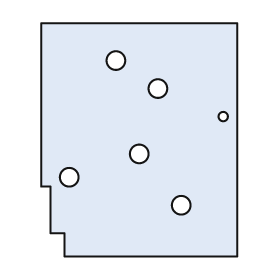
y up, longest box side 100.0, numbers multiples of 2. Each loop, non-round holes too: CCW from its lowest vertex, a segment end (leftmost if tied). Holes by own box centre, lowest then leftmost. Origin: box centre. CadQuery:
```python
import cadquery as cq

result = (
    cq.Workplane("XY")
    .moveTo(-32.0, -50.0)
    .lineTo(42.0, -50.0)
    .lineTo(42.0, 50.0)
    .lineTo(-42.0, 50.0)
    .lineTo(-42.0, -20.0)
    .lineTo(-38.0, -20.0)
    .lineTo(-38.0, -40.0)
    .lineTo(-32.0, -40.0)
    .close()
    .moveTo(18.0, -28.0)
    .circle(4.0)
    .moveTo(-30.0, -16.0)
    .circle(4.0)
    .moveTo(0.0, -6.0)
    .circle(4.0)
    .moveTo(36.0, 10.0)
    .circle(2.0)
    .moveTo(8.0, 22.0)
    .circle(4.0)
    .moveTo(-10.0, 34.0)
    .circle(4.0)
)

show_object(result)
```